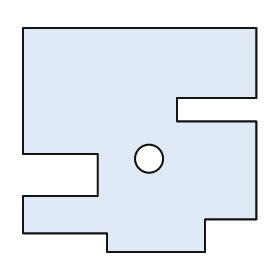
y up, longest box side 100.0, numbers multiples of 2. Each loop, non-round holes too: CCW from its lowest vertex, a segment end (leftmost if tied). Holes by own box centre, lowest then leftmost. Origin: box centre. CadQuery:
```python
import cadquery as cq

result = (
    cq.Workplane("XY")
    .moveTo(-14.0, -48.0)
    .lineTo(28.0, -48.0)
    .lineTo(28.0, -34.0)
    .lineTo(50.0, -34.0)
    .lineTo(50.0, 8.0)
    .lineTo(16.0, 8.0)
    .lineTo(16.0, 18.0)
    .lineTo(50.0, 18.0)
    .lineTo(50.0, 48.0)
    .lineTo(-50.0, 48.0)
    .lineTo(-50.0, -6.0)
    .lineTo(-18.0, -6.0)
    .lineTo(-18.0, -24.0)
    .lineTo(-50.0, -24.0)
    .lineTo(-50.0, -40.0)
    .lineTo(-14.0, -40.0)
    .close()
    .moveTo(4.0, -8.0)
    .circle(6.0)
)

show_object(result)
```